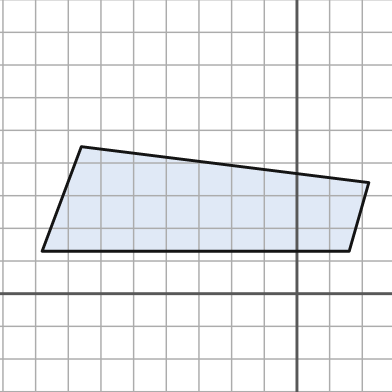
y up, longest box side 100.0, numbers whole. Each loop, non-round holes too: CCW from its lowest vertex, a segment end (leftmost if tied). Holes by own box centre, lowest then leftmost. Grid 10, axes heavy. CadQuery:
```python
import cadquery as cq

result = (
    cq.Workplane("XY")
    .moveTo(-78.0, 13.0)
    .lineTo(16.0, 13.0)
    .lineTo(22.0, 34.0)
    .lineTo(-66.0, 45.0)
    .close()
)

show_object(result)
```